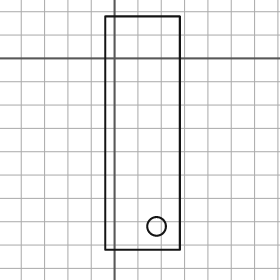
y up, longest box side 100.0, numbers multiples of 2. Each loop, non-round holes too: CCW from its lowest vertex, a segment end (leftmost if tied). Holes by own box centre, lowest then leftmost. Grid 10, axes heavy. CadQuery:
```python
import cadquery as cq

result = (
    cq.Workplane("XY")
    .moveTo(-4.0, -82.0)
    .lineTo(28.0, -82.0)
    .lineTo(28.0, 18.0)
    .lineTo(-4.0, 18.0)
    .close()
    .moveTo(18.0, -72.0)
    .circle(4.0)
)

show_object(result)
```